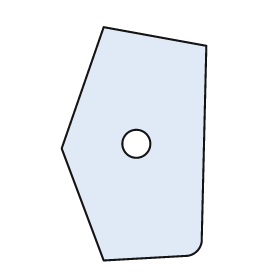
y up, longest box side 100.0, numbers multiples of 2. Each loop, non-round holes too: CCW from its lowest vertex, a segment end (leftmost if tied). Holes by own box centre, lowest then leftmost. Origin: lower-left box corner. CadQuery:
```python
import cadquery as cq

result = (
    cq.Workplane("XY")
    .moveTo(18.0, 0.0)
    .lineTo(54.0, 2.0)
    .threePointArc((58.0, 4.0), (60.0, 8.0))
    .lineTo(62.0, 92.0)
    .lineTo(18.0, 100.0)
    .lineTo(0.0, 48.0)
    .close()
    .moveTo(32.0, 50.0)
    .circle(6.0)
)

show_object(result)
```